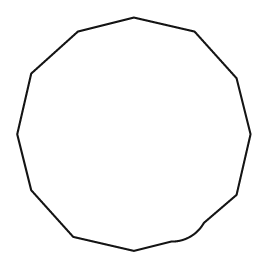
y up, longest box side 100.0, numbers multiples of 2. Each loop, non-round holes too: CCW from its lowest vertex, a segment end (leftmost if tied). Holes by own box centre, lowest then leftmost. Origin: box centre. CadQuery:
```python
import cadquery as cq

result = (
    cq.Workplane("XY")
    .moveTo(0.0, -50.0)
    .lineTo(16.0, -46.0)
    .threePointArc((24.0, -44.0), (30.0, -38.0))
    .lineTo(44.0, -26.0)
    .lineTo(50.0, 0.0)
    .lineTo(44.0, 24.0)
    .lineTo(26.0, 44.0)
    .lineTo(0.0, 50.0)
    .lineTo(-24.0, 44.0)
    .lineTo(-44.0, 26.0)
    .lineTo(-50.0, 0.0)
    .lineTo(-44.0, -24.0)
    .lineTo(-26.0, -44.0)
    .close()
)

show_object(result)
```